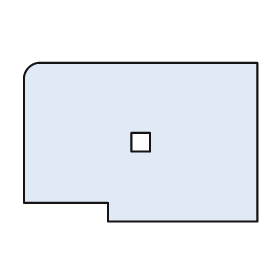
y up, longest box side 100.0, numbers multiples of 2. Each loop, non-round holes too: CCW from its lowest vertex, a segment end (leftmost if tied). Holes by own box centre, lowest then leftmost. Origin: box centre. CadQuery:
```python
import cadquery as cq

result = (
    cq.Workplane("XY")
    .moveTo(-14.0, -34.0)
    .lineTo(50.0, -34.0)
    .lineTo(50.0, 34.0)
    .lineTo(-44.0, 34.0)
    .threePointArc((-48.0, 32.0), (-50.0, 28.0))
    .lineTo(-50.0, -26.0)
    .lineTo(-14.0, -26.0)
    .close()
    .moveTo(-4.0, -4.0)
    .lineTo(4.0, -4.0)
    .lineTo(4.0, 4.0)
    .lineTo(-4.0, 4.0)
    .close()
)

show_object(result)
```